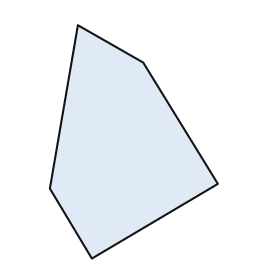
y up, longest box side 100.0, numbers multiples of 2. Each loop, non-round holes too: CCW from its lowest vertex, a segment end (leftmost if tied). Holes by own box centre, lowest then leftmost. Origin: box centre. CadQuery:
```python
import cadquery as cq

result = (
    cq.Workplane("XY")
    .moveTo(-18.0, -50.0)
    .lineTo(36.0, -18.0)
    .lineTo(4.0, 34.0)
    .lineTo(-24.0, 50.0)
    .lineTo(-36.0, -20.0)
    .close()
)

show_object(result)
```